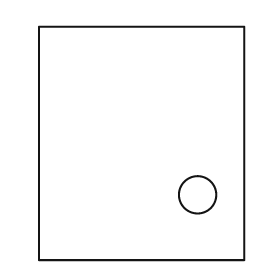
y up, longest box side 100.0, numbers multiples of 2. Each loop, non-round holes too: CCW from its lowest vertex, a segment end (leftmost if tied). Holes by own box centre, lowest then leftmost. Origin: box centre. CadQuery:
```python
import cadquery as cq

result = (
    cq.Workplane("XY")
    .moveTo(-44.0, -50.0)
    .lineTo(44.0, -50.0)
    .lineTo(44.0, 50.0)
    .lineTo(-44.0, 50.0)
    .close()
    .moveTo(24.0, -22.0)
    .circle(8.0)
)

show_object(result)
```